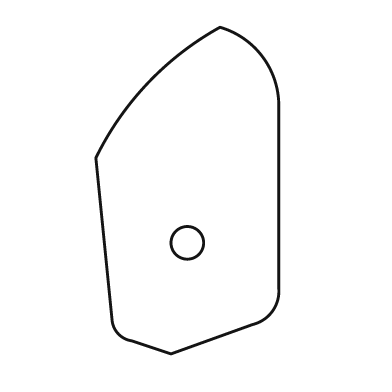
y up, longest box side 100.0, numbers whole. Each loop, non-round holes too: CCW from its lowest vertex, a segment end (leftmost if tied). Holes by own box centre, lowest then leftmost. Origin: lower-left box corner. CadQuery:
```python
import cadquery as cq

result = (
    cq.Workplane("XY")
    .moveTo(23.0, 0.0)
    .lineTo(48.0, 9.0)
    .threePointArc((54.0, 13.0), (56.0, 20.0))
    .lineTo(56.0, 76.0)
    .threePointArc((51.0, 91.0), (38.0, 100.0))
    .threePointArc((16.0, 83.0), (0.0, 60.0))
    .lineTo(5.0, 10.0)
    .threePointArc((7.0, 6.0), (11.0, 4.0))
    .close()
    .moveTo(28.0, 34.0)
    .circle(5.0)
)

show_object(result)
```